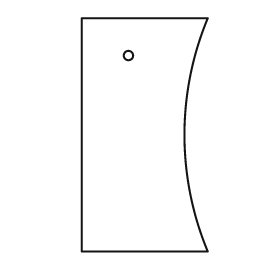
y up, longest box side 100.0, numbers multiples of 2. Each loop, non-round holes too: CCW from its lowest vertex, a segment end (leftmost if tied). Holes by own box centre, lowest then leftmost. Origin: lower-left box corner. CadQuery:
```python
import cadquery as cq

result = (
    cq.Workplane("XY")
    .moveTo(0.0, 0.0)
    .lineTo(54.0, 0.0)
    .threePointArc((44.0, 50.0), (54.0, 100.0))
    .lineTo(0.0, 100.0)
    .close()
    .moveTo(20.0, 84.0)
    .circle(2.0)
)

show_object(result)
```